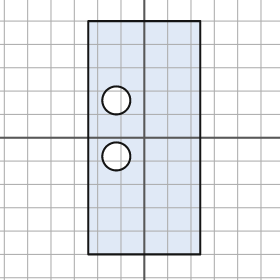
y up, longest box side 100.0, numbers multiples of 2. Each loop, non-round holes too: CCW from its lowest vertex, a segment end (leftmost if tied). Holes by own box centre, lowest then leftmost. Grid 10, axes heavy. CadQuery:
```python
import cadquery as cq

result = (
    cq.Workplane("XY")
    .moveTo(-24.0, -50.0)
    .lineTo(24.0, -50.0)
    .lineTo(24.0, 50.0)
    .lineTo(-24.0, 50.0)
    .close()
    .moveTo(-12.0, -8.0)
    .circle(6.0)
    .moveTo(-12.0, 16.0)
    .circle(6.0)
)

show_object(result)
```